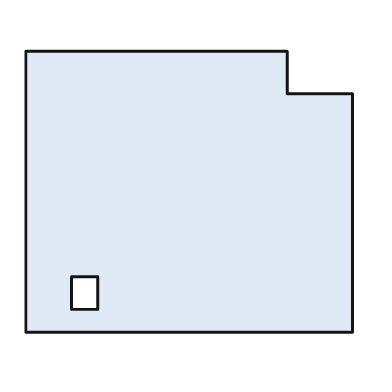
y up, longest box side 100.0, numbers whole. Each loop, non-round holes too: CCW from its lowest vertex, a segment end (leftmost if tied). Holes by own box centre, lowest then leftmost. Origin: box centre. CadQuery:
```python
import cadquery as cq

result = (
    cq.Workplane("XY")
    .moveTo(-50.0, -43.0)
    .lineTo(50.0, -43.0)
    .lineTo(50.0, 30.0)
    .lineTo(30.0, 30.0)
    .lineTo(30.0, 43.0)
    .lineTo(-50.0, 43.0)
    .close()
    .moveTo(-36.0, -36.0)
    .lineTo(-28.0, -36.0)
    .lineTo(-28.0, -26.0)
    .lineTo(-36.0, -26.0)
    .close()
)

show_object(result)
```